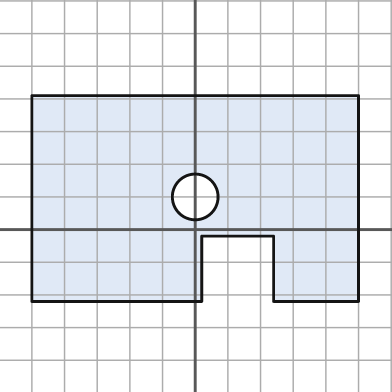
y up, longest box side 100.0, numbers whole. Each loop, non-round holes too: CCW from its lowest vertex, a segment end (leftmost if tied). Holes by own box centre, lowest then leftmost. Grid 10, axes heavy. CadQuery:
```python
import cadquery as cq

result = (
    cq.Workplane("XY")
    .moveTo(-50.0, -22.0)
    .lineTo(2.0, -22.0)
    .lineTo(2.0, -2.0)
    .lineTo(24.0, -2.0)
    .lineTo(24.0, -22.0)
    .lineTo(50.0, -22.0)
    .lineTo(50.0, 41.0)
    .lineTo(-50.0, 41.0)
    .close()
    .moveTo(0.0, 10.0)
    .circle(7.0)
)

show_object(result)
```